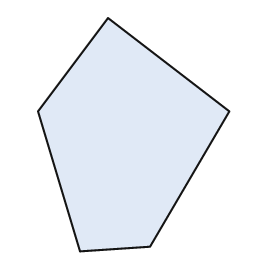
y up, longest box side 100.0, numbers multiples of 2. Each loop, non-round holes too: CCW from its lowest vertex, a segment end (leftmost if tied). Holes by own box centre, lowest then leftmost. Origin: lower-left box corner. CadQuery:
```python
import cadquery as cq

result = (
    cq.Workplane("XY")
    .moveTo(18.0, 0.0)
    .lineTo(48.0, 2.0)
    .lineTo(82.0, 60.0)
    .lineTo(30.0, 100.0)
    .lineTo(0.0, 60.0)
    .close()
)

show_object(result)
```